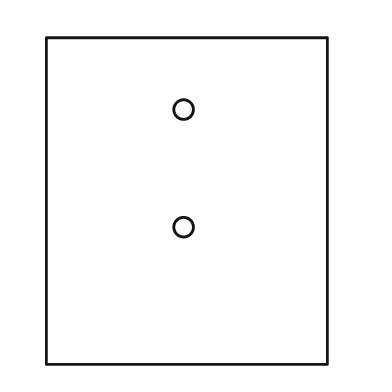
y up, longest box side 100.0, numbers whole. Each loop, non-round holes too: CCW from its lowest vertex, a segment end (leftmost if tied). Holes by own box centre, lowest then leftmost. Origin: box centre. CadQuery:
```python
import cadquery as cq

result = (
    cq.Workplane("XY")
    .moveTo(-43.0, -50.0)
    .lineTo(43.0, -50.0)
    .lineTo(43.0, 50.0)
    .lineTo(-43.0, 50.0)
    .close()
    .moveTo(-1.0, -8.0)
    .circle(3.0)
    .moveTo(-1.0, 28.0)
    .circle(3.0)
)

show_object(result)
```